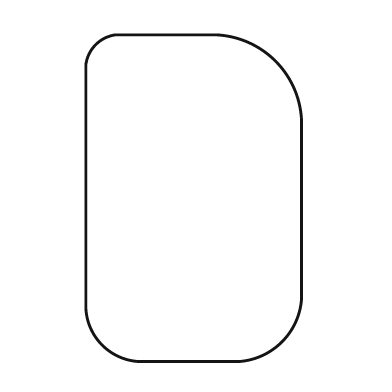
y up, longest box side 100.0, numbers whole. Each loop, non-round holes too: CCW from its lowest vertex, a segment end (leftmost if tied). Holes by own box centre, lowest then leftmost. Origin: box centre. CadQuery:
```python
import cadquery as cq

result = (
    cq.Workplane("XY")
    .moveTo(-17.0, -50.0)
    .lineTo(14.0, -50.0)
    .threePointArc((27.0, -44.0), (33.0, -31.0))
    .lineTo(33.0, 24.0)
    .threePointArc((25.0, 42.0), (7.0, 50.0))
    .lineTo(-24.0, 50.0)
    .threePointArc((-30.0, 47.0), (-33.0, 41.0))
    .lineTo(-33.0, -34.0)
    .threePointArc((-28.0, -45.0), (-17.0, -50.0))
    .close()
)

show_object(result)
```